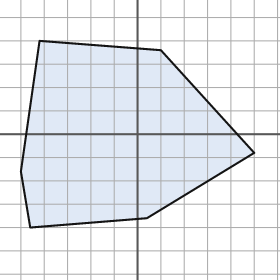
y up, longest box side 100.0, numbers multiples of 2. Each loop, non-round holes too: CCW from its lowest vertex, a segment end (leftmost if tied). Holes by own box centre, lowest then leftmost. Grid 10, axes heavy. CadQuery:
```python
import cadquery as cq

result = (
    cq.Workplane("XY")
    .moveTo(-46.0, -40.0)
    .lineTo(4.0, -36.0)
    .lineTo(50.0, -8.0)
    .lineTo(10.0, 36.0)
    .lineTo(-42.0, 40.0)
    .lineTo(-50.0, -16.0)
    .close()
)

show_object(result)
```